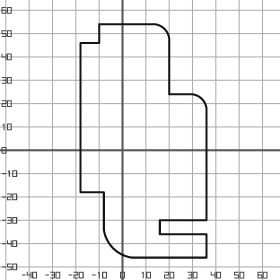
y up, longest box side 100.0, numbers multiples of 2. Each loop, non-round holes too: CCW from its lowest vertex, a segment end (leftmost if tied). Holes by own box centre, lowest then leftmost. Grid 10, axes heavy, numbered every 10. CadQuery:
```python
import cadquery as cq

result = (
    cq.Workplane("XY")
    .moveTo(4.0, -46.0)
    .lineTo(36.0, -46.0)
    .lineTo(36.0, -36.0)
    .lineTo(16.0, -36.0)
    .lineTo(16.0, -30.0)
    .lineTo(36.0, -30.0)
    .lineTo(36.0, 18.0)
    .threePointArc((34.0, 22.0), (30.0, 24.0))
    .lineTo(20.0, 24.0)
    .lineTo(20.0, 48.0)
    .threePointArc((18.0, 52.0), (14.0, 54.0))
    .lineTo(-10.0, 54.0)
    .lineTo(-10.0, 46.0)
    .lineTo(-18.0, 46.0)
    .lineTo(-18.0, -18.0)
    .lineTo(-8.0, -18.0)
    .lineTo(-8.0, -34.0)
    .threePointArc((-4.0, -42.0), (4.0, -46.0))
    .close()
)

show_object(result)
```